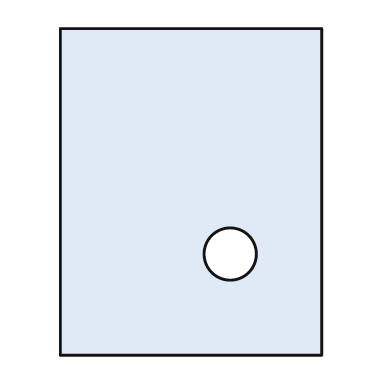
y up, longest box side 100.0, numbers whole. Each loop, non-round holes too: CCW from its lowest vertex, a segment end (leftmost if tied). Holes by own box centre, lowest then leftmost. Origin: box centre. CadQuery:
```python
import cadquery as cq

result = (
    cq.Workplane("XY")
    .moveTo(-40.0, -50.0)
    .lineTo(40.0, -50.0)
    .lineTo(40.0, 50.0)
    .lineTo(-40.0, 50.0)
    .close()
    .moveTo(12.0, -19.0)
    .circle(8.0)
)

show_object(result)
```